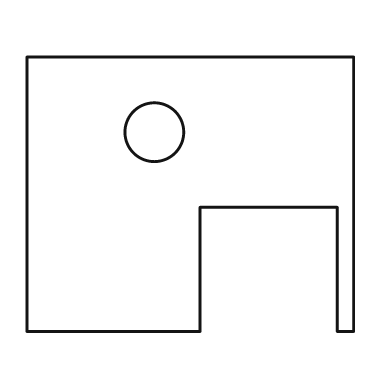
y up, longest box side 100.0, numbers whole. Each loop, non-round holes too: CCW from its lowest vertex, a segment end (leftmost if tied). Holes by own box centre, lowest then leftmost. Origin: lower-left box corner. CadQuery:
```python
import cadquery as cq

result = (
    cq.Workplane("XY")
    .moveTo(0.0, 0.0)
    .lineTo(53.0, 0.0)
    .lineTo(53.0, 38.0)
    .lineTo(95.0, 38.0)
    .lineTo(95.0, 0.0)
    .lineTo(100.0, 0.0)
    .lineTo(100.0, 84.0)
    .lineTo(0.0, 84.0)
    .close()
    .moveTo(39.0, 61.0)
    .circle(9.0)
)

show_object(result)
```